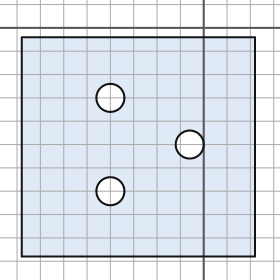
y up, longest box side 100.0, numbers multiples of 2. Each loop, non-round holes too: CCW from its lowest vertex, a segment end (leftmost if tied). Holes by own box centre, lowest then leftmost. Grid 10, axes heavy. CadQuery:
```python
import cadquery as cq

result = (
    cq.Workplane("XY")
    .moveTo(-78.0, -98.0)
    .lineTo(22.0, -98.0)
    .lineTo(22.0, -4.0)
    .lineTo(-78.0, -4.0)
    .close()
    .moveTo(-40.0, -70.0)
    .circle(6.0)
    .moveTo(-6.0, -50.0)
    .circle(6.0)
    .moveTo(-40.0, -30.0)
    .circle(6.0)
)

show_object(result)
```